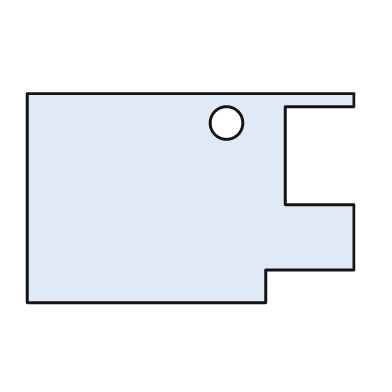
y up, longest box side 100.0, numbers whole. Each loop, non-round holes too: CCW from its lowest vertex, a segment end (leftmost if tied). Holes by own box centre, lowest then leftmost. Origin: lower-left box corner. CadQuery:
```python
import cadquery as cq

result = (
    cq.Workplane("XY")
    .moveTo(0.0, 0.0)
    .lineTo(73.0, 0.0)
    .lineTo(73.0, 10.0)
    .lineTo(100.0, 10.0)
    .lineTo(100.0, 30.0)
    .lineTo(79.0, 30.0)
    .lineTo(79.0, 60.0)
    .lineTo(100.0, 60.0)
    .lineTo(100.0, 64.0)
    .lineTo(0.0, 64.0)
    .close()
    .moveTo(61.0, 55.0)
    .circle(5.0)
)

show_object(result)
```